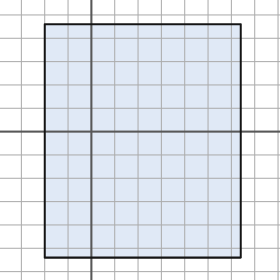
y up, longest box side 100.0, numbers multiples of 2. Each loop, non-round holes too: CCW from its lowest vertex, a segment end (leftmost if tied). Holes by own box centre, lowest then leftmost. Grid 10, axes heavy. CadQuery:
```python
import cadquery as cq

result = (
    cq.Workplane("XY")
    .moveTo(-20.0, -54.0)
    .lineTo(64.0, -54.0)
    .lineTo(64.0, 46.0)
    .lineTo(-20.0, 46.0)
    .close()
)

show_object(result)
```